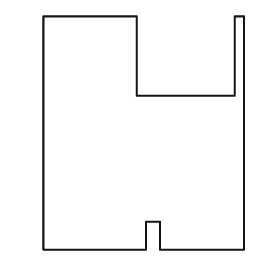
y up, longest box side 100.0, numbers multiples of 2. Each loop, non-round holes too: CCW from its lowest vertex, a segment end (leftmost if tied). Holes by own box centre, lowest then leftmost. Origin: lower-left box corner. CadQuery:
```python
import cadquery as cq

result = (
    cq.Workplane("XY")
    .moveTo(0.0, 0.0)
    .lineTo(44.0, 0.0)
    .lineTo(44.0, 12.0)
    .lineTo(50.0, 12.0)
    .lineTo(50.0, 0.0)
    .lineTo(86.0, 0.0)
    .lineTo(86.0, 100.0)
    .lineTo(82.0, 100.0)
    .lineTo(82.0, 66.0)
    .lineTo(40.0, 66.0)
    .lineTo(40.0, 100.0)
    .lineTo(0.0, 100.0)
    .close()
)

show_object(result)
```